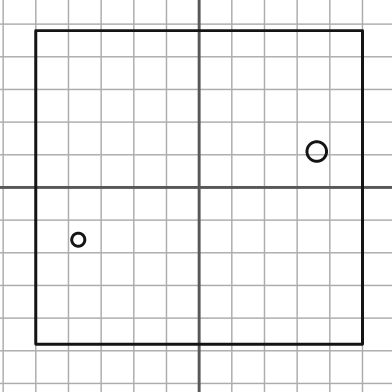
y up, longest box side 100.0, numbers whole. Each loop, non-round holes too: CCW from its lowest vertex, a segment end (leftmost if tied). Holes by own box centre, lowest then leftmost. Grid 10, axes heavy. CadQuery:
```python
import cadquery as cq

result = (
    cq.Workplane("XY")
    .moveTo(-50.0, -48.0)
    .lineTo(50.0, -48.0)
    .lineTo(50.0, 48.0)
    .lineTo(-50.0, 48.0)
    .close()
    .moveTo(-37.0, -16.0)
    .circle(2.0)
    .moveTo(36.0, 11.0)
    .circle(3.0)
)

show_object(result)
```